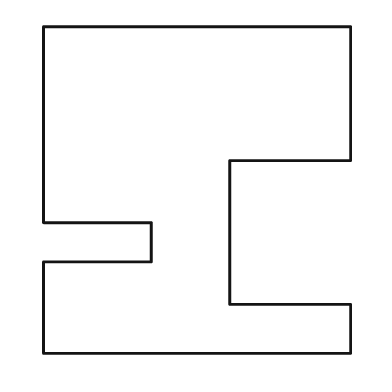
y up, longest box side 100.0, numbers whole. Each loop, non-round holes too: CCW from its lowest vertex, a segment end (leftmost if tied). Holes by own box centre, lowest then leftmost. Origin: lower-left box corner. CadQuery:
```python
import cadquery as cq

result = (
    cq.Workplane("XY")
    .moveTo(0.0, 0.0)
    .lineTo(94.0, 0.0)
    .lineTo(94.0, 15.0)
    .lineTo(57.0, 15.0)
    .lineTo(57.0, 59.0)
    .lineTo(94.0, 59.0)
    .lineTo(94.0, 100.0)
    .lineTo(0.0, 100.0)
    .lineTo(0.0, 40.0)
    .lineTo(33.0, 40.0)
    .lineTo(33.0, 28.0)
    .lineTo(0.0, 28.0)
    .close()
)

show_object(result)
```